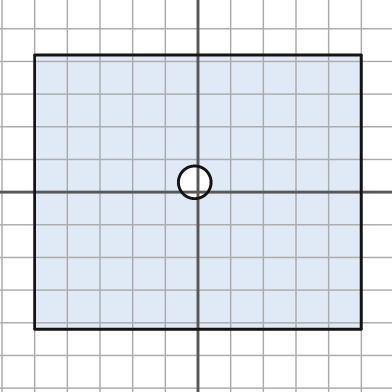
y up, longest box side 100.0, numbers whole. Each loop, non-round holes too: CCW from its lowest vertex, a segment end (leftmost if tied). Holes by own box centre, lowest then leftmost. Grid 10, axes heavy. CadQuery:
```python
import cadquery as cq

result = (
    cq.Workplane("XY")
    .moveTo(-50.0, -42.0)
    .lineTo(50.0, -42.0)
    .lineTo(50.0, 42.0)
    .lineTo(-50.0, 42.0)
    .close()
    .moveTo(-1.0, 3.0)
    .circle(5.0)
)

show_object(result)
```